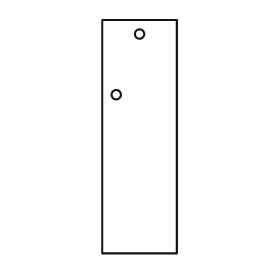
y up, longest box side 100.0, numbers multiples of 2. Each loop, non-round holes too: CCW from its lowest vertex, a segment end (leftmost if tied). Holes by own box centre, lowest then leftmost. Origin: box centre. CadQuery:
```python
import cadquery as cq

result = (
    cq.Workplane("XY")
    .moveTo(-16.0, -50.0)
    .lineTo(16.0, -50.0)
    .lineTo(16.0, 50.0)
    .lineTo(-16.0, 50.0)
    .close()
    .moveTo(-10.0, 18.0)
    .circle(2.0)
    .moveTo(0.0, 44.0)
    .circle(2.0)
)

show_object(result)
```